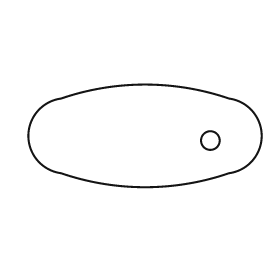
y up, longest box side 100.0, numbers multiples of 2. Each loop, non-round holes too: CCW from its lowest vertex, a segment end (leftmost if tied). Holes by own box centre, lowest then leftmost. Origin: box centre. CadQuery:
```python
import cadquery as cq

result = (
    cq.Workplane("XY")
    .moveTo(-36.0, -16.0)
    .threePointArc((0.0, -22.0), (36.0, -16.0))
    .threePointArc((50.0, 0.0), (36.0, 16.0))
    .threePointArc((0.0, 22.0), (-36.0, 16.0))
    .threePointArc((-50.0, 0.0), (-36.0, -16.0))
    .close()
    .moveTo(28.0, -2.0)
    .circle(4.0)
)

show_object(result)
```